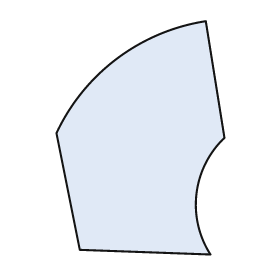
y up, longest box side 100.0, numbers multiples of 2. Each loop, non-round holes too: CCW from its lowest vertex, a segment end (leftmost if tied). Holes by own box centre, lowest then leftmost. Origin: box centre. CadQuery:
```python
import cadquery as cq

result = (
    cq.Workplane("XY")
    .moveTo(30.0, -50.0)
    .threePointArc((24.0, -24.0), (36.0, 0.0))
    .lineTo(28.0, 50.0)
    .threePointArc((-10.0, 34.0), (-36.0, 2.0))
    .lineTo(-26.0, -48.0)
    .close()
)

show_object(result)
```